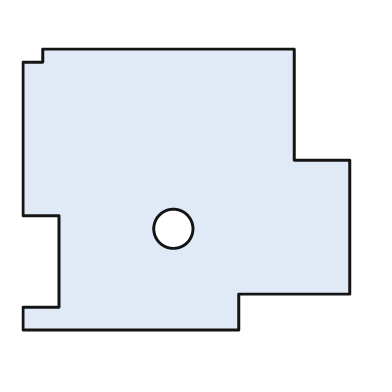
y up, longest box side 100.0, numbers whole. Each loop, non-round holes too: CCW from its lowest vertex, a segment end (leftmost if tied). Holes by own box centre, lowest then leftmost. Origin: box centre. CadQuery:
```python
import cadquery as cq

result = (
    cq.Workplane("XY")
    .moveTo(-50.0, -43.0)
    .lineTo(16.0, -43.0)
    .lineTo(16.0, -32.0)
    .lineTo(50.0, -32.0)
    .lineTo(50.0, 9.0)
    .lineTo(33.0, 9.0)
    .lineTo(33.0, 43.0)
    .lineTo(-44.0, 43.0)
    .lineTo(-44.0, 39.0)
    .lineTo(-50.0, 39.0)
    .lineTo(-50.0, -8.0)
    .lineTo(-39.0, -8.0)
    .lineTo(-39.0, -36.0)
    .lineTo(-50.0, -36.0)
    .close()
    .moveTo(-4.0, -12.0)
    .circle(6.0)
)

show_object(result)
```